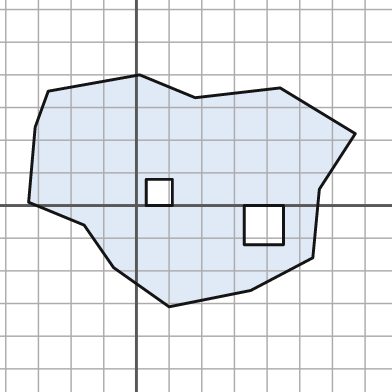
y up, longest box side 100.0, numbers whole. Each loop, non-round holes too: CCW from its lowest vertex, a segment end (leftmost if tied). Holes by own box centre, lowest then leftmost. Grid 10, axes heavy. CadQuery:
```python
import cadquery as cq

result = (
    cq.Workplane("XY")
    .moveTo(10.0, -31.0)
    .lineTo(35.0, -26.0)
    .lineTo(54.0, -16.0)
    .lineTo(56.0, 5.0)
    .lineTo(67.0, 22.0)
    .lineTo(44.0, 36.0)
    .lineTo(18.0, 33.0)
    .lineTo(1.0, 40.0)
    .lineTo(-27.0, 35.0)
    .lineTo(-31.0, 24.0)
    .lineTo(-33.0, 1.0)
    .lineTo(-16.0, -6.0)
    .lineTo(-7.0, -19.0)
    .close()
    .moveTo(33.0, -12.0)
    .lineTo(45.0, -12.0)
    .lineTo(45.0, 0.0)
    .lineTo(33.0, 0.0)
    .close()
    .moveTo(3.0, 0.0)
    .lineTo(11.0, 0.0)
    .lineTo(11.0, 8.0)
    .lineTo(3.0, 8.0)
    .close()
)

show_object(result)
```